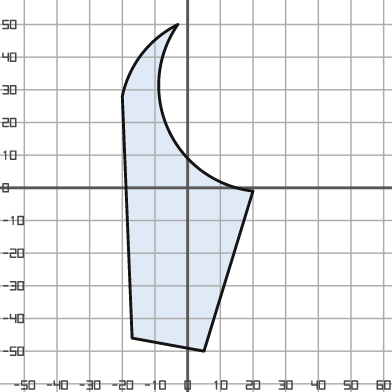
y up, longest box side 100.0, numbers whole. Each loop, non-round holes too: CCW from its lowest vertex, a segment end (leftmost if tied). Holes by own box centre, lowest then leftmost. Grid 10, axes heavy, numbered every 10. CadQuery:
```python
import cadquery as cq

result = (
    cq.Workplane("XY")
    .moveTo(5.0, -50.0)
    .lineTo(20.0, -1.0)
    .threePointArc((-6.0, 18.0), (-3.0, 50.0))
    .threePointArc((-14.0, 41.0), (-20.0, 28.0))
    .lineTo(-17.0, -46.0)
    .close()
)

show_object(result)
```